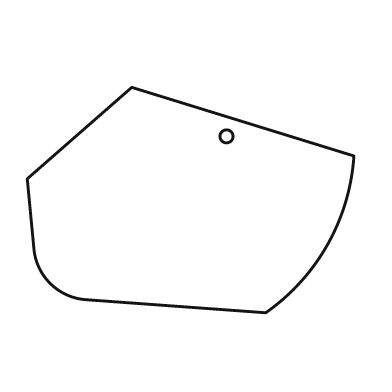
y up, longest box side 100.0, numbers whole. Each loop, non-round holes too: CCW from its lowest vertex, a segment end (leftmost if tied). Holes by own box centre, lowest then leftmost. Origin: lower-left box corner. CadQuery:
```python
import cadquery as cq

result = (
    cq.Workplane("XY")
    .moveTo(73.0, 0.0)
    .threePointArc((92.0, 21.0), (100.0, 48.0))
    .lineTo(32.0, 69.0)
    .lineTo(0.0, 41.0)
    .lineTo(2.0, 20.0)
    .threePointArc((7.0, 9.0), (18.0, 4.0))
    .close()
    .moveTo(61.0, 54.0)
    .circle(2.0)
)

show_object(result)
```